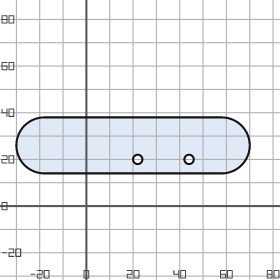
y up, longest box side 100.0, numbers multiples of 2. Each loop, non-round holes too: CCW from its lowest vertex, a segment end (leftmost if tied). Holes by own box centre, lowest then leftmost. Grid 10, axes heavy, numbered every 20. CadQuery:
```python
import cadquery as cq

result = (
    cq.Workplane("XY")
    .moveTo(-18.0, 14.0)
    .lineTo(58.0, 14.0)
    .threePointArc((70.0, 26.0), (58.0, 38.0))
    .lineTo(-18.0, 38.0)
    .threePointArc((-30.0, 26.0), (-18.0, 14.0))
    .close()
    .moveTo(22.0, 20.0)
    .circle(2.0)
    .moveTo(44.0, 20.0)
    .circle(2.0)
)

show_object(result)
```